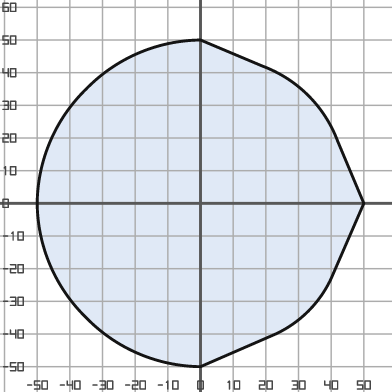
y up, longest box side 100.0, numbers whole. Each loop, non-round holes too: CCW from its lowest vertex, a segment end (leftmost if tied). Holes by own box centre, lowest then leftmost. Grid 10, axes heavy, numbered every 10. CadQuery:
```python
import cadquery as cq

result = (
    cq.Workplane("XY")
    .moveTo(0.0, -50.0)
    .lineTo(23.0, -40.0)
    .threePointArc((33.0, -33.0), (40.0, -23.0))
    .lineTo(50.0, 0.0)
    .lineTo(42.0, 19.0)
    .threePointArc((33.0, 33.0), (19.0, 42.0))
    .lineTo(0.0, 50.0)
    .threePointArc((-19.0, 46.0), (-35.0, 35.0))
    .threePointArc((-46.0, 19.0), (-50.0, 0.0))
    .threePointArc((-46.0, -19.0), (-35.0, -35.0))
    .threePointArc((-19.0, -46.0), (0.0, -50.0))
    .close()
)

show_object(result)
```